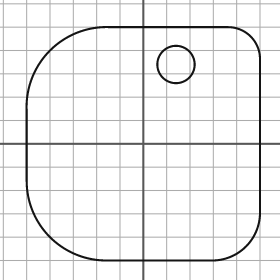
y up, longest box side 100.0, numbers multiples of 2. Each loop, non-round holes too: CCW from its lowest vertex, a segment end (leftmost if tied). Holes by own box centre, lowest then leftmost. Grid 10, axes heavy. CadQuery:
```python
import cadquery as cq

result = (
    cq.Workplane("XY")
    .moveTo(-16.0, -50.0)
    .lineTo(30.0, -50.0)
    .threePointArc((44.0, -44.0), (50.0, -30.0))
    .lineTo(50.0, 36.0)
    .threePointArc((46.0, 46.0), (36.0, 50.0))
    .lineTo(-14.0, 50.0)
    .threePointArc((-40.0, 40.0), (-50.0, 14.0))
    .lineTo(-50.0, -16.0)
    .threePointArc((-40.0, -40.0), (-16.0, -50.0))
    .close()
    .moveTo(14.0, 34.0)
    .circle(8.0)
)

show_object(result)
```